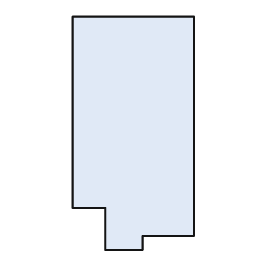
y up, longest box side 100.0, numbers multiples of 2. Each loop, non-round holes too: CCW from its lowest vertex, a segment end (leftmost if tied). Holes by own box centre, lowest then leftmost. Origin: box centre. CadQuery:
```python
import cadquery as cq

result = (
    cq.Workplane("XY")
    .moveTo(-12.0, -50.0)
    .lineTo(4.0, -50.0)
    .lineTo(4.0, -44.0)
    .lineTo(26.0, -44.0)
    .lineTo(26.0, 50.0)
    .lineTo(-26.0, 50.0)
    .lineTo(-26.0, -32.0)
    .lineTo(-12.0, -32.0)
    .close()
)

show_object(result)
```